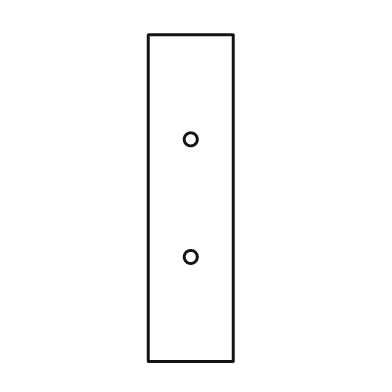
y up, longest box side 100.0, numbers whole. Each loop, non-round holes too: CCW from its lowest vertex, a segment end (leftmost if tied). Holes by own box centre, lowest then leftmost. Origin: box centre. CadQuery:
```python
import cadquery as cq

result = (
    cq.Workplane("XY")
    .moveTo(-13.0, -50.0)
    .lineTo(13.0, -50.0)
    .lineTo(13.0, 50.0)
    .lineTo(-13.0, 50.0)
    .close()
    .moveTo(0.0, -18.0)
    .circle(2.0)
    .moveTo(0.0, 18.0)
    .circle(2.0)
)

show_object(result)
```